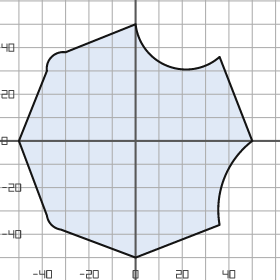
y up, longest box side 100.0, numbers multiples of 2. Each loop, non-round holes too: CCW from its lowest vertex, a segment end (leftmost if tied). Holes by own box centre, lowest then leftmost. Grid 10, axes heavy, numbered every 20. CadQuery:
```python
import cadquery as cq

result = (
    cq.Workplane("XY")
    .moveTo(0.0, -50.0)
    .lineTo(36.0, -36.0)
    .threePointArc((38.0, -16.0), (50.0, 0.0))
    .lineTo(36.0, 36.0)
    .threePointArc((14.0, 32.0), (0.0, 50.0))
    .lineTo(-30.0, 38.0)
    .threePointArc((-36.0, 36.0), (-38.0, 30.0))
    .lineTo(-50.0, 0.0)
    .lineTo(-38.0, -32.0)
    .threePointArc((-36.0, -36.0), (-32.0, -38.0))
    .close()
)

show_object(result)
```